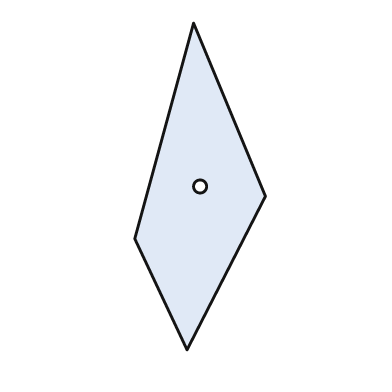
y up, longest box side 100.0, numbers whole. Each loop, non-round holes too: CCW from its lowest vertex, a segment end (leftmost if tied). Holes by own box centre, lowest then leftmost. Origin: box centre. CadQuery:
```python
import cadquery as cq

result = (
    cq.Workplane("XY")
    .moveTo(-4.0, -50.0)
    .lineTo(20.0, -3.0)
    .lineTo(-2.0, 50.0)
    .lineTo(-20.0, -16.0)
    .close()
    .moveTo(0.0, 0.0)
    .circle(2.0)
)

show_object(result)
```